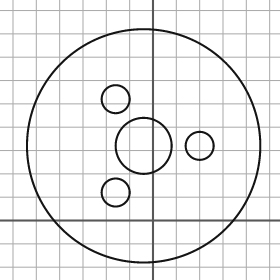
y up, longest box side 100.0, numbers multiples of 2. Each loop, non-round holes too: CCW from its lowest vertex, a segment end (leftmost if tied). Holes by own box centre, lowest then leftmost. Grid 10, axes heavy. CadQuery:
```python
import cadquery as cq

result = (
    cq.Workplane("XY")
    .moveTo(-4.0, 32.0)
    .circle(50.0)
    .moveTo(-16.0, 12.0)
    .circle(6.0)
    .moveTo(-4.0, 32.0)
    .circle(12.0)
    .moveTo(20.0, 32.0)
    .circle(6.0)
    .moveTo(-16.0, 52.0)
    .circle(6.0)
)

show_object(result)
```